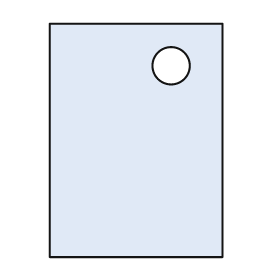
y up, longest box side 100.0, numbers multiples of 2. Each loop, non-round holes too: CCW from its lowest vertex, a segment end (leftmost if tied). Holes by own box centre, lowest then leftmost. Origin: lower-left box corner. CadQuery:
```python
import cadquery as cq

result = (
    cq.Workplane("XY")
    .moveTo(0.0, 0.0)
    .lineTo(74.0, 0.0)
    .lineTo(74.0, 100.0)
    .lineTo(0.0, 100.0)
    .close()
    .moveTo(52.0, 82.0)
    .circle(8.0)
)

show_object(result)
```